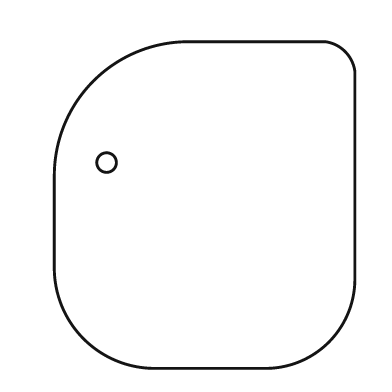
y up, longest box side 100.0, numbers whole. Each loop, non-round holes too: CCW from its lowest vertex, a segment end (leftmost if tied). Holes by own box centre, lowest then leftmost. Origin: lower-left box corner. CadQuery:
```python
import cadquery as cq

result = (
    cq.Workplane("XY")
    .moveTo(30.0, 0.0)
    .lineTo(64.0, 0.0)
    .threePointArc((84.0, 8.0), (92.0, 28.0))
    .lineTo(92.0, 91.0)
    .threePointArc((89.0, 97.0), (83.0, 100.0))
    .lineTo(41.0, 100.0)
    .threePointArc((12.0, 88.0), (0.0, 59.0))
    .lineTo(0.0, 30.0)
    .threePointArc((9.0, 9.0), (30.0, 0.0))
    .close()
    .moveTo(16.0, 63.0)
    .circle(3.0)
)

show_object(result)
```